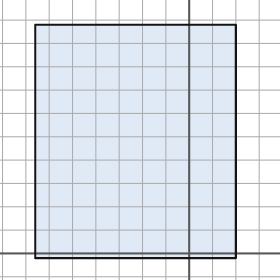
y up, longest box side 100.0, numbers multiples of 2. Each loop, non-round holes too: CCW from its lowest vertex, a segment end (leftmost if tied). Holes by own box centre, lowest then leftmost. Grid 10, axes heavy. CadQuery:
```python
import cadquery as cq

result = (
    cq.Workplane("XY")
    .moveTo(-66.0, -2.0)
    .lineTo(20.0, -2.0)
    .lineTo(20.0, 98.0)
    .lineTo(-66.0, 98.0)
    .close()
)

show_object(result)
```